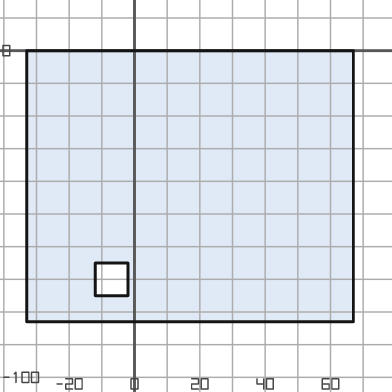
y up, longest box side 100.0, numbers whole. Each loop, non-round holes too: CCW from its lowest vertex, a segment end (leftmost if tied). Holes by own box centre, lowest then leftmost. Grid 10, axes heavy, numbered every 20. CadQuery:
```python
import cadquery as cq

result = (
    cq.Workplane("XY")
    .moveTo(-33.0, -83.0)
    .lineTo(67.0, -83.0)
    .lineTo(67.0, 0.0)
    .lineTo(-33.0, 0.0)
    .close()
    .moveTo(-12.0, -75.0)
    .lineTo(-2.0, -75.0)
    .lineTo(-2.0, -65.0)
    .lineTo(-12.0, -65.0)
    .close()
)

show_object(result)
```